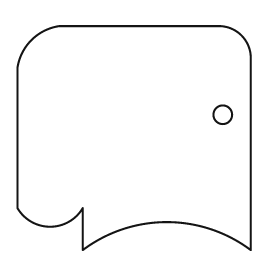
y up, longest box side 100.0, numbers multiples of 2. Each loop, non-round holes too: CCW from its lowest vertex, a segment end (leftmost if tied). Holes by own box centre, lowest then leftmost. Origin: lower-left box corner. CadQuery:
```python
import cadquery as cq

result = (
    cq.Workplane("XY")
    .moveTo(28.0, 0.0)
    .threePointArc((64.0, 12.0), (100.0, 0.0))
    .lineTo(100.0, 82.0)
    .threePointArc((96.0, 92.0), (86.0, 96.0))
    .lineTo(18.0, 96.0)
    .threePointArc((6.0, 90.0), (0.0, 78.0))
    .lineTo(0.0, 18.0)
    .threePointArc((14.0, 10.0), (28.0, 18.0))
    .close()
    .moveTo(88.0, 58.0)
    .circle(4.0)
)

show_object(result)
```